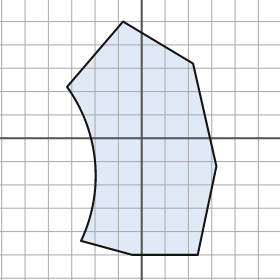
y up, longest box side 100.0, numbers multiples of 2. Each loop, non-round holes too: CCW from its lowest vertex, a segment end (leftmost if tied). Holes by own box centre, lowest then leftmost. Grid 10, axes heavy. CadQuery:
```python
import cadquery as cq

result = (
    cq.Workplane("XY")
    .moveTo(-4.0, -50.0)
    .lineTo(24.0, -50.0)
    .lineTo(32.0, -12.0)
    .lineTo(22.0, 32.0)
    .lineTo(-8.0, 50.0)
    .lineTo(-32.0, 22.0)
    .threePointArc((-20.0, -10.0), (-26.0, -44.0))
    .close()
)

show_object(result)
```